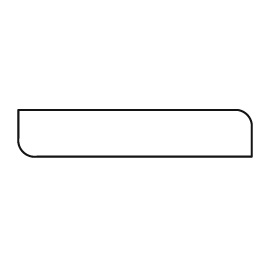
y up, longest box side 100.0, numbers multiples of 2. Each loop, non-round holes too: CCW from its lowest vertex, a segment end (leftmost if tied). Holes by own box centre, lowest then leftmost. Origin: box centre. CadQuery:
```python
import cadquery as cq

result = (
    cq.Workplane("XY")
    .moveTo(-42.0, -10.0)
    .lineTo(50.0, -10.0)
    .lineTo(50.0, 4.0)
    .threePointArc((48.0, 8.0), (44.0, 10.0))
    .lineTo(-50.0, 10.0)
    .lineTo(-50.0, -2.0)
    .threePointArc((-48.0, -8.0), (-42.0, -10.0))
    .close()
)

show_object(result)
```